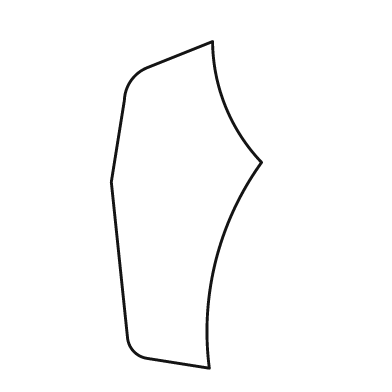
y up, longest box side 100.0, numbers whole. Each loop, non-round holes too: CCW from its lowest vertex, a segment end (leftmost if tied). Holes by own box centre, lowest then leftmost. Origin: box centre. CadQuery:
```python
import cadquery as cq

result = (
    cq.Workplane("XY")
    .moveTo(7.0, -50.0)
    .threePointArc((9.0, -17.0), (23.0, 13.0))
    .threePointArc((12.0, 30.0), (8.0, 50.0))
    .lineTo(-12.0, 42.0)
    .threePointArc((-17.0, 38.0), (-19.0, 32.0))
    .lineTo(-23.0, 7.0)
    .lineTo(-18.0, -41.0)
    .threePointArc((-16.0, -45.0), (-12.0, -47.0))
    .close()
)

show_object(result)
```